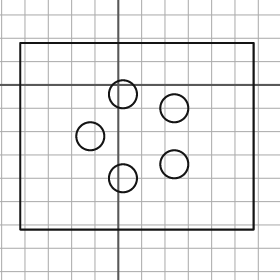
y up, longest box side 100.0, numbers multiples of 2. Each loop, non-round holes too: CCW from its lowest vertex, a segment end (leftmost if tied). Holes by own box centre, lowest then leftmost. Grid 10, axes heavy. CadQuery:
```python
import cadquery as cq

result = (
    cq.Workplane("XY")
    .moveTo(-42.0, -62.0)
    .lineTo(58.0, -62.0)
    .lineTo(58.0, 18.0)
    .lineTo(-42.0, 18.0)
    .close()
    .moveTo(2.0, -40.0)
    .circle(6.0)
    .moveTo(24.0, -34.0)
    .circle(6.0)
    .moveTo(-12.0, -22.0)
    .circle(6.0)
    .moveTo(24.0, -10.0)
    .circle(6.0)
    .moveTo(2.0, -4.0)
    .circle(6.0)
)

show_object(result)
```